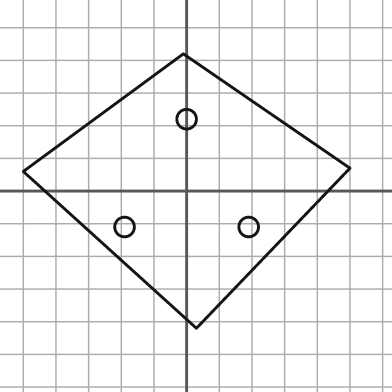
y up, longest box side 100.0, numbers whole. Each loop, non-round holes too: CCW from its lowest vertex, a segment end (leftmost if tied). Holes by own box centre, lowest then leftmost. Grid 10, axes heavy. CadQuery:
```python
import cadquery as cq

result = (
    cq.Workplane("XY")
    .moveTo(3.0, -42.0)
    .lineTo(50.0, 7.0)
    .lineTo(-1.0, 42.0)
    .lineTo(-50.0, 6.0)
    .close()
    .moveTo(-19.0, -11.0)
    .circle(3.0)
    .moveTo(19.0, -11.0)
    .circle(3.0)
    .moveTo(0.0, 22.0)
    .circle(3.0)
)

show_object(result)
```